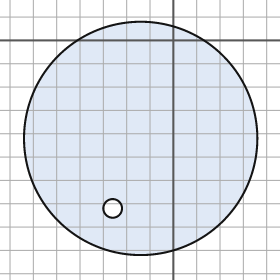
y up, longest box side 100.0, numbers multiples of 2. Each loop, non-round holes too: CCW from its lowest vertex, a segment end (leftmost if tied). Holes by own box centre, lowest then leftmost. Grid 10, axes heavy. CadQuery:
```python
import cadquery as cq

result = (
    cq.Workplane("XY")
    .moveTo(-14.0, -42.0)
    .circle(50.0)
    .moveTo(-26.0, -72.0)
    .circle(4.0)
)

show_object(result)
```